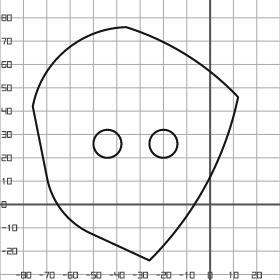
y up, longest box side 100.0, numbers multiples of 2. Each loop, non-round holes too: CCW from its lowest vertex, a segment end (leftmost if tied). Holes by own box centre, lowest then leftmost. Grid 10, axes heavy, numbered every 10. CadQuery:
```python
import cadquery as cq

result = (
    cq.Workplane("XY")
    .moveTo(-26.0, -24.0)
    .threePointArc((-2.0, 8.0), (12.0, 46.0))
    .threePointArc((-10.0, 64.0), (-36.0, 76.0))
    .threePointArc((-62.0, 66.0), (-76.0, 42.0))
    .lineTo(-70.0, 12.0)
    .threePointArc((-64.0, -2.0), (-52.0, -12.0))
    .close()
    .moveTo(-44.0, 26.0)
    .circle(6.0)
    .moveTo(-20.0, 26.0)
    .circle(6.0)
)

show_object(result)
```